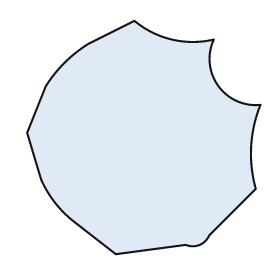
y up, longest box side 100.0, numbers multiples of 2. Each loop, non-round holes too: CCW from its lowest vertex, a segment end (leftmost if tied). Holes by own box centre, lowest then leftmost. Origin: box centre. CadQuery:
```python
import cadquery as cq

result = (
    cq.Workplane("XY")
    .moveTo(-12.0, -50.0)
    .lineTo(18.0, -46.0)
    .threePointArc((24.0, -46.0), (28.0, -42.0))
    .lineTo(48.0, -22.0)
    .threePointArc((46.0, -4.0), (50.0, 14.0))
    .threePointArc((32.0, 22.0), (30.0, 42.0))
    .threePointArc((12.0, 42.0), (-4.0, 50.0))
    .lineTo(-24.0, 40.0)
    .threePointArc((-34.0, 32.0), (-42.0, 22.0))
    .lineTo(-50.0, 2.0)
    .lineTo(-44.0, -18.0)
    .threePointArc((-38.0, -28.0), (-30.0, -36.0))
    .close()
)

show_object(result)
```